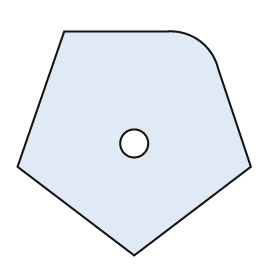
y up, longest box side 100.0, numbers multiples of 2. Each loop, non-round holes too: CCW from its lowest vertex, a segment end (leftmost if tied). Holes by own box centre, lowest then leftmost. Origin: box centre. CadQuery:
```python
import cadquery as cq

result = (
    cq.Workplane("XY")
    .moveTo(0.0, -48.0)
    .lineTo(50.0, -10.0)
    .lineTo(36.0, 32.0)
    .threePointArc((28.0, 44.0), (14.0, 48.0))
    .lineTo(-30.0, 48.0)
    .lineTo(-50.0, -10.0)
    .close()
    .moveTo(0.0, 0.0)
    .circle(6.0)
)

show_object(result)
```